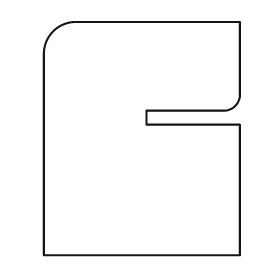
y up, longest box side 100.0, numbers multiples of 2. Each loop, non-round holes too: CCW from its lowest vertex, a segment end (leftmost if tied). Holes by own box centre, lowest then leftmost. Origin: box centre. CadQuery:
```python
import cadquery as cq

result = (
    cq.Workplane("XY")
    .moveTo(-42.0, -50.0)
    .lineTo(42.0, -50.0)
    .lineTo(42.0, 6.0)
    .lineTo(2.0, 6.0)
    .lineTo(2.0, 12.0)
    .lineTo(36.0, 12.0)
    .threePointArc((40.0, 14.0), (42.0, 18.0))
    .lineTo(42.0, 50.0)
    .lineTo(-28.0, 50.0)
    .threePointArc((-38.0, 46.0), (-42.0, 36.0))
    .close()
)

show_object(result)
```